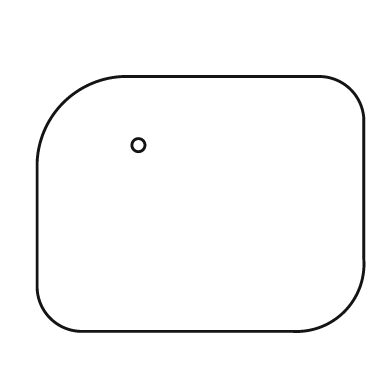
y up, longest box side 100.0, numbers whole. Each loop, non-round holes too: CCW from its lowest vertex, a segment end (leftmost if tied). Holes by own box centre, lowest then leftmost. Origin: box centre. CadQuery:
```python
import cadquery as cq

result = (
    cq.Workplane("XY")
    .moveTo(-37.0, -39.0)
    .lineTo(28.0, -39.0)
    .threePointArc((44.0, -33.0), (50.0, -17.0))
    .lineTo(50.0, 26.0)
    .threePointArc((46.0, 35.0), (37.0, 39.0))
    .lineTo(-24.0, 39.0)
    .threePointArc((-42.0, 31.0), (-50.0, 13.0))
    .lineTo(-50.0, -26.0)
    .threePointArc((-46.0, -35.0), (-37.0, -39.0))
    .close()
    .moveTo(-19.0, 18.0)
    .circle(2.0)
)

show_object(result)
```